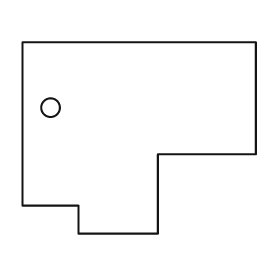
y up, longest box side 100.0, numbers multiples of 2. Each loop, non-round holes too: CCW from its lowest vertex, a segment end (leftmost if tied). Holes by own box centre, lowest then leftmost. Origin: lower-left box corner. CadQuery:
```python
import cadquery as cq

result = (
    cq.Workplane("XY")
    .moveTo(24.0, 0.0)
    .lineTo(58.0, 0.0)
    .lineTo(58.0, 34.0)
    .lineTo(100.0, 34.0)
    .lineTo(100.0, 82.0)
    .lineTo(0.0, 82.0)
    .lineTo(0.0, 12.0)
    .lineTo(24.0, 12.0)
    .close()
    .moveTo(12.0, 54.0)
    .circle(4.0)
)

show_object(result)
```